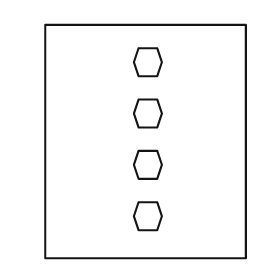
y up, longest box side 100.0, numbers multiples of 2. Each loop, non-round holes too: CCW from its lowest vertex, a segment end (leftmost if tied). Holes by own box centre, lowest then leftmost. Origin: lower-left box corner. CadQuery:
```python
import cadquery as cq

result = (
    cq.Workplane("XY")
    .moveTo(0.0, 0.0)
    .lineTo(86.0, 0.0)
    .lineTo(86.0, 100.0)
    .lineTo(0.0, 100.0)
    .close()
    .moveTo(40.0, 12.0)
    .lineTo(48.0, 12.0)
    .lineTo(50.0, 18.0)
    .lineTo(48.0, 24.0)
    .lineTo(40.0, 24.0)
    .lineTo(38.0, 18.0)
    .close()
    .moveTo(40.0, 34.0)
    .lineTo(48.0, 34.0)
    .lineTo(50.0, 40.0)
    .lineTo(48.0, 46.0)
    .lineTo(40.0, 46.0)
    .lineTo(38.0, 40.0)
    .close()
    .moveTo(40.0, 56.0)
    .lineTo(48.0, 56.0)
    .lineTo(50.0, 62.0)
    .lineTo(48.0, 68.0)
    .lineTo(40.0, 68.0)
    .lineTo(38.0, 62.0)
    .close()
    .moveTo(40.0, 78.0)
    .lineTo(48.0, 78.0)
    .lineTo(50.0, 84.0)
    .lineTo(48.0, 90.0)
    .lineTo(40.0, 90.0)
    .lineTo(38.0, 84.0)
    .close()
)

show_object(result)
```